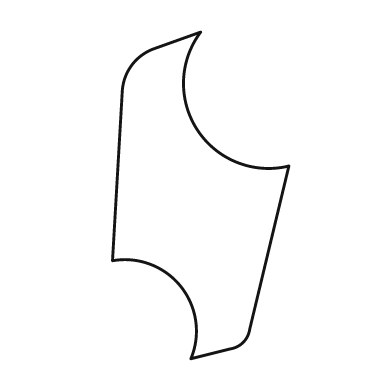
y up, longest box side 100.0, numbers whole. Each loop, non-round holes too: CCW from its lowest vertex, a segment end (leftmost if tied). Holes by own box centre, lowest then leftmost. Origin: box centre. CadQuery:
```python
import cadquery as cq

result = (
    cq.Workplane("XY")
    .moveTo(-3.0, -50.0)
    .lineTo(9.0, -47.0)
    .threePointArc((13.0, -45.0), (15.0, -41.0))
    .lineTo(27.0, 9.0)
    .threePointArc((-1.0, 20.0), (0.0, 50.0))
    .lineTo(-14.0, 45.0)
    .threePointArc((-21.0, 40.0), (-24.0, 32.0))
    .lineTo(-27.0, -20.0)
    .threePointArc((-6.0, -28.0), (-3.0, -50.0))
    .close()
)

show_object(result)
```